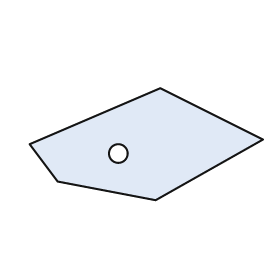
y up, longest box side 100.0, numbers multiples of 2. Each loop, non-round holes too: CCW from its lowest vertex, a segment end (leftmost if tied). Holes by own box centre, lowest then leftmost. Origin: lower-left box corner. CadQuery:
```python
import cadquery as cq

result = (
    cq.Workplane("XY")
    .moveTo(54.0, 0.0)
    .lineTo(100.0, 26.0)
    .lineTo(56.0, 48.0)
    .lineTo(0.0, 24.0)
    .lineTo(12.0, 8.0)
    .close()
    .moveTo(38.0, 20.0)
    .circle(4.0)
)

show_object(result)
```